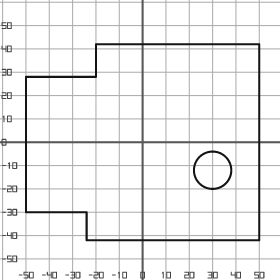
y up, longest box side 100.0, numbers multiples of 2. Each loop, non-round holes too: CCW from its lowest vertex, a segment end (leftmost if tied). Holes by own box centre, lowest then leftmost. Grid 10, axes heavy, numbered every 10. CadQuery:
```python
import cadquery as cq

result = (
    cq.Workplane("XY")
    .moveTo(-24.0, -42.0)
    .lineTo(50.0, -42.0)
    .lineTo(50.0, 42.0)
    .lineTo(-20.0, 42.0)
    .lineTo(-20.0, 28.0)
    .lineTo(-50.0, 28.0)
    .lineTo(-50.0, -30.0)
    .lineTo(-24.0, -30.0)
    .close()
    .moveTo(30.0, -12.0)
    .circle(8.0)
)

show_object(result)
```